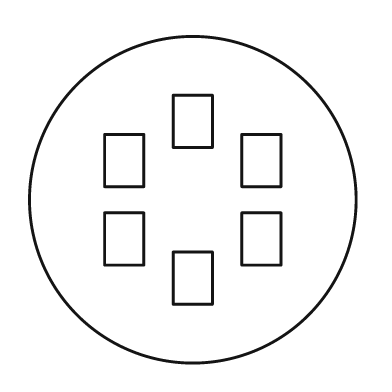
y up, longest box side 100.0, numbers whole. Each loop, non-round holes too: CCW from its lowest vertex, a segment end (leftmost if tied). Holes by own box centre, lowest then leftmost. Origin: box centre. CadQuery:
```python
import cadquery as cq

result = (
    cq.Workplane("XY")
    .moveTo(0.0, 0.0)
    .circle(50.0)
    .moveTo(-6.0, -32.0)
    .lineTo(6.0, -32.0)
    .lineTo(6.0, -16.0)
    .lineTo(-6.0, -16.0)
    .close()
    .moveTo(-27.0, -20.0)
    .lineTo(-15.0, -20.0)
    .lineTo(-15.0, -4.0)
    .lineTo(-27.0, -4.0)
    .close()
    .moveTo(15.0, -20.0)
    .lineTo(27.0, -20.0)
    .lineTo(27.0, -4.0)
    .lineTo(15.0, -4.0)
    .close()
    .moveTo(-27.0, 4.0)
    .lineTo(-15.0, 4.0)
    .lineTo(-15.0, 20.0)
    .lineTo(-27.0, 20.0)
    .close()
    .moveTo(15.0, 4.0)
    .lineTo(27.0, 4.0)
    .lineTo(27.0, 20.0)
    .lineTo(15.0, 20.0)
    .close()
    .moveTo(-6.0, 16.0)
    .lineTo(6.0, 16.0)
    .lineTo(6.0, 32.0)
    .lineTo(-6.0, 32.0)
    .close()
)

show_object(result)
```